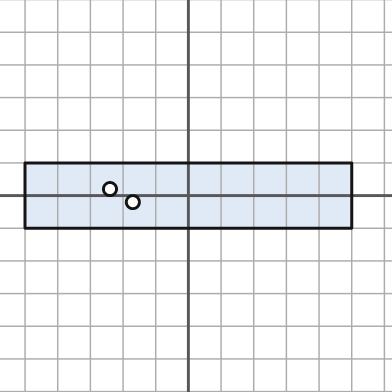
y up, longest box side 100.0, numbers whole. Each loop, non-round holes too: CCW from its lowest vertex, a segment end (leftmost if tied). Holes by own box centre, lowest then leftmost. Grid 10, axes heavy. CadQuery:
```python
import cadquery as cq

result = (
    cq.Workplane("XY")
    .moveTo(-50.0, -10.0)
    .lineTo(50.0, -10.0)
    .lineTo(50.0, 10.0)
    .lineTo(-50.0, 10.0)
    .close()
    .moveTo(-17.0, -2.0)
    .circle(2.0)
    .moveTo(-24.0, 2.0)
    .circle(2.0)
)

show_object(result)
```